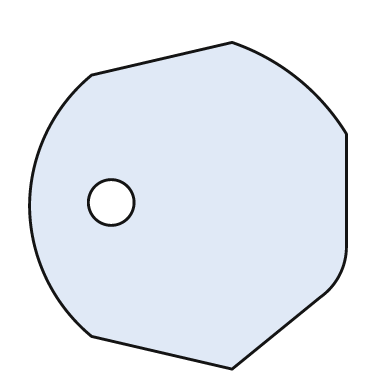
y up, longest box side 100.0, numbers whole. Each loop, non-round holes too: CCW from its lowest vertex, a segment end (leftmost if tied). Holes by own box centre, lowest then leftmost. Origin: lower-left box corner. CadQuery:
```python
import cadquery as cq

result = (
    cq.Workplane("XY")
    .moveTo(62.0, 0.0)
    .lineTo(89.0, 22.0)
    .threePointArc((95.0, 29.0), (97.0, 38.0))
    .lineTo(97.0, 72.0)
    .threePointArc((82.0, 89.0), (62.0, 100.0))
    .lineTo(19.0, 90.0)
    .threePointArc((5.0, 72.0), (0.0, 50.0))
    .threePointArc((5.0, 28.0), (19.0, 10.0))
    .close()
    .moveTo(25.0, 51.0)
    .circle(7.0)
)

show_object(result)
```